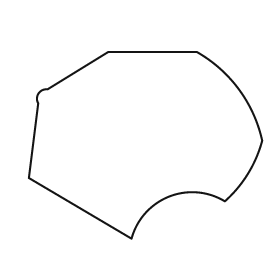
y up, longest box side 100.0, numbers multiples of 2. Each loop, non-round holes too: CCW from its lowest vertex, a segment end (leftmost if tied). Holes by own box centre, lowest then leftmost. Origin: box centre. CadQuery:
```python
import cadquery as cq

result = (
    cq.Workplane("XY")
    .moveTo(-6.0, -40.0)
    .threePointArc((10.0, -22.0), (34.0, -24.0))
    .threePointArc((44.0, -12.0), (50.0, 2.0))
    .threePointArc((40.0, 24.0), (22.0, 40.0))
    .lineTo(-16.0, 40.0)
    .lineTo(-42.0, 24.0)
    .threePointArc((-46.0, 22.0), (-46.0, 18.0))
    .lineTo(-50.0, -14.0)
    .close()
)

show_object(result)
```